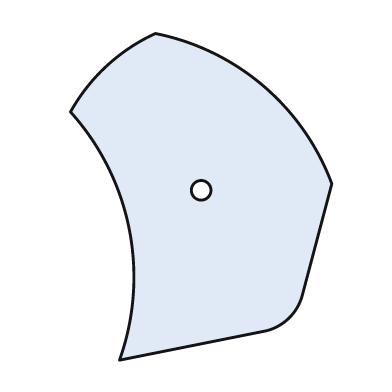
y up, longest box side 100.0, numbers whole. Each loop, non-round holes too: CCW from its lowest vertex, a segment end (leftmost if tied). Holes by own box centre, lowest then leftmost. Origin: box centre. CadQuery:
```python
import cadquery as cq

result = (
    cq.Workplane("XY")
    .moveTo(-25.0, -50.0)
    .lineTo(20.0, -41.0)
    .threePointArc((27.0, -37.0), (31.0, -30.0))
    .lineTo(40.0, 4.0)
    .threePointArc((19.0, 34.0), (-14.0, 50.0))
    .threePointArc((-29.0, 40.0), (-40.0, 26.0))
    .threePointArc((-22.0, -10.0), (-25.0, -50.0))
    .close()
    .moveTo(0.0, 2.0)
    .circle(3.0)
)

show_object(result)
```